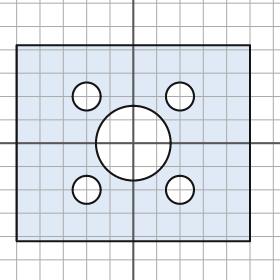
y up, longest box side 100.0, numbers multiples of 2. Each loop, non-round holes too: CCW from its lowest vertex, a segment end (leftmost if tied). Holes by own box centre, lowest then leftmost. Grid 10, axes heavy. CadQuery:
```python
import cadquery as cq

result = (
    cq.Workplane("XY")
    .moveTo(-50.0, -42.0)
    .lineTo(50.0, -42.0)
    .lineTo(50.0, 42.0)
    .lineTo(-50.0, 42.0)
    .close()
    .moveTo(-20.0, -20.0)
    .circle(6.0)
    .moveTo(20.0, -20.0)
    .circle(6.0)
    .moveTo(0.0, 0.0)
    .circle(16.0)
    .moveTo(-20.0, 20.0)
    .circle(6.0)
    .moveTo(20.0, 20.0)
    .circle(6.0)
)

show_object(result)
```